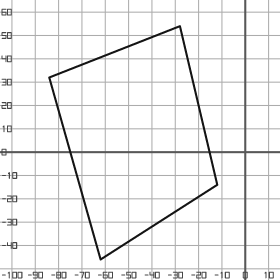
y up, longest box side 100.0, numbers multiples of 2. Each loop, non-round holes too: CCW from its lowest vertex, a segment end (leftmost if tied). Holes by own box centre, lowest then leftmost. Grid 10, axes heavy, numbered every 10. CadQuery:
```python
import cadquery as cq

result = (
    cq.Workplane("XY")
    .moveTo(-62.0, -46.0)
    .lineTo(-12.0, -14.0)
    .lineTo(-28.0, 54.0)
    .lineTo(-84.0, 32.0)
    .close()
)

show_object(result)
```